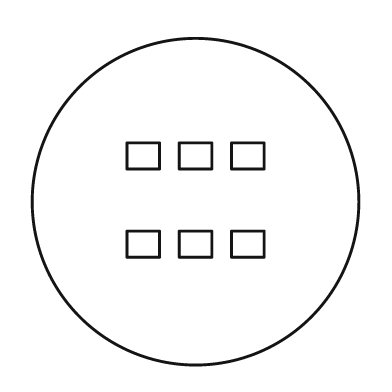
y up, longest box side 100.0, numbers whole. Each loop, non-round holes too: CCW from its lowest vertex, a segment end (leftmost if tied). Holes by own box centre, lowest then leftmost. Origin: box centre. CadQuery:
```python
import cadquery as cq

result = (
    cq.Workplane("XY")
    .moveTo(0.0, 0.0)
    .circle(50.0)
    .moveTo(-21.0, -17.0)
    .lineTo(-11.0, -17.0)
    .lineTo(-11.0, -9.0)
    .lineTo(-21.0, -9.0)
    .close()
    .moveTo(-5.0, -17.0)
    .lineTo(5.0, -17.0)
    .lineTo(5.0, -9.0)
    .lineTo(-5.0, -9.0)
    .close()
    .moveTo(11.0, -17.0)
    .lineTo(21.0, -17.0)
    .lineTo(21.0, -9.0)
    .lineTo(11.0, -9.0)
    .close()
    .moveTo(-21.0, 10.0)
    .lineTo(-11.0, 10.0)
    .lineTo(-11.0, 18.0)
    .lineTo(-21.0, 18.0)
    .close()
    .moveTo(-5.0, 10.0)
    .lineTo(5.0, 10.0)
    .lineTo(5.0, 18.0)
    .lineTo(-5.0, 18.0)
    .close()
    .moveTo(11.0, 10.0)
    .lineTo(21.0, 10.0)
    .lineTo(21.0, 18.0)
    .lineTo(11.0, 18.0)
    .close()
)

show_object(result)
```